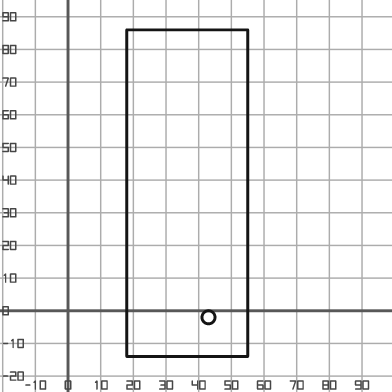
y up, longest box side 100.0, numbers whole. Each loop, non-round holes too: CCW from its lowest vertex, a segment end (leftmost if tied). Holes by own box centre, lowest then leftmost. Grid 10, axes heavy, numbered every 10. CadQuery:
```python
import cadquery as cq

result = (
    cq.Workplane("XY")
    .moveTo(18.0, -14.0)
    .lineTo(55.0, -14.0)
    .lineTo(55.0, 86.0)
    .lineTo(18.0, 86.0)
    .close()
    .moveTo(43.0, -2.0)
    .circle(2.0)
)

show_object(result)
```